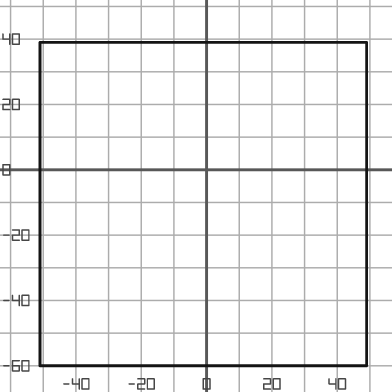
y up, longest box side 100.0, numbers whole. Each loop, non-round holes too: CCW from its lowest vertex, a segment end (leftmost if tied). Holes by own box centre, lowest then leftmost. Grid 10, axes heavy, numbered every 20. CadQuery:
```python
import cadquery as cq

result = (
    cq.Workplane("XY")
    .moveTo(-51.0, -60.0)
    .lineTo(49.0, -60.0)
    .lineTo(49.0, 39.0)
    .lineTo(-51.0, 39.0)
    .close()
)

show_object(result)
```